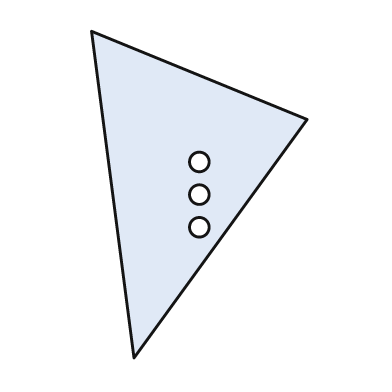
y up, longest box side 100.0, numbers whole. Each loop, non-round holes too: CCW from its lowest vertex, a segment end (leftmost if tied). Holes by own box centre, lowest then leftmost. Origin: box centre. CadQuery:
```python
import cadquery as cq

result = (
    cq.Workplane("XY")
    .moveTo(-20.0, -50.0)
    .lineTo(33.0, 23.0)
    .lineTo(-33.0, 50.0)
    .close()
    .moveTo(0.0, -10.0)
    .circle(3.0)
    .moveTo(0.0, 0.0)
    .circle(3.0)
    .moveTo(0.0, 10.0)
    .circle(3.0)
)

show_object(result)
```